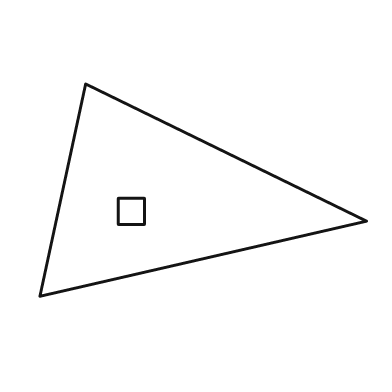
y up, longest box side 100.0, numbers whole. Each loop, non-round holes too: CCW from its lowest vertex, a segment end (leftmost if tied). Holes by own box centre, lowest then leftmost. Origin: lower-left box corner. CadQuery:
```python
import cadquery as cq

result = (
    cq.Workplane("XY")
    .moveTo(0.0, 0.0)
    .lineTo(100.0, 23.0)
    .lineTo(14.0, 65.0)
    .close()
    .moveTo(24.0, 22.0)
    .lineTo(32.0, 22.0)
    .lineTo(32.0, 30.0)
    .lineTo(24.0, 30.0)
    .close()
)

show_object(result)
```